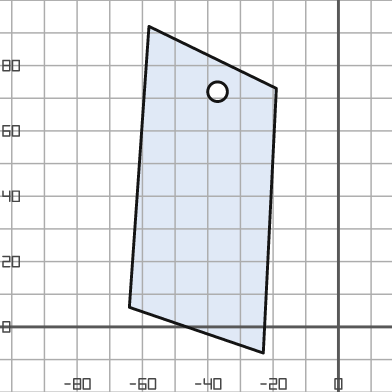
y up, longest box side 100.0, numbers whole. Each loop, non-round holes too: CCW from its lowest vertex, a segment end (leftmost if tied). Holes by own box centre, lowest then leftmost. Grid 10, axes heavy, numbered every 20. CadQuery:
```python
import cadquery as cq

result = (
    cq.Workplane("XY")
    .moveTo(-23.0, -8.0)
    .lineTo(-19.0, 73.0)
    .lineTo(-58.0, 92.0)
    .lineTo(-64.0, 6.0)
    .close()
    .moveTo(-37.0, 72.0)
    .circle(3.0)
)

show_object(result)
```